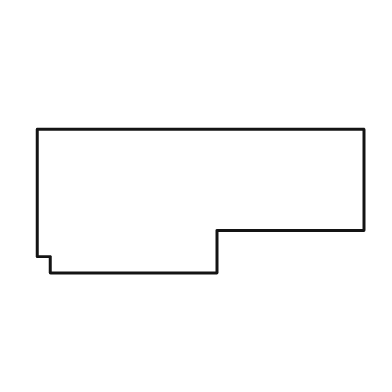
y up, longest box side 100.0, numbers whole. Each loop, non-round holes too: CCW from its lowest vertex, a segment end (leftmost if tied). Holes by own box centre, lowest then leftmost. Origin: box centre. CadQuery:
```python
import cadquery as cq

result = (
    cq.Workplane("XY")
    .moveTo(-46.0, -22.0)
    .lineTo(5.0, -22.0)
    .lineTo(5.0, -9.0)
    .lineTo(50.0, -9.0)
    .lineTo(50.0, 22.0)
    .lineTo(-50.0, 22.0)
    .lineTo(-50.0, -17.0)
    .lineTo(-46.0, -17.0)
    .close()
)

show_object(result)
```